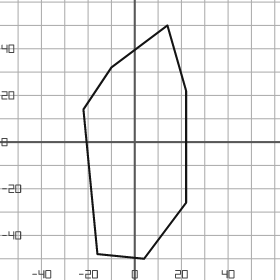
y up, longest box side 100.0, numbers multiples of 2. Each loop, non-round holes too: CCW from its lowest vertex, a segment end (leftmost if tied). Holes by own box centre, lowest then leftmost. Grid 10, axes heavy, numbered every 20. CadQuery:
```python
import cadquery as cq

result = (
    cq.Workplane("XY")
    .moveTo(4.0, -50.0)
    .lineTo(22.0, -26.0)
    .lineTo(22.0, 22.0)
    .lineTo(14.0, 50.0)
    .lineTo(-10.0, 32.0)
    .lineTo(-22.0, 14.0)
    .lineTo(-16.0, -48.0)
    .close()
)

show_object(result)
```